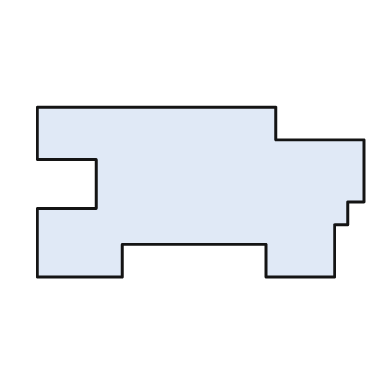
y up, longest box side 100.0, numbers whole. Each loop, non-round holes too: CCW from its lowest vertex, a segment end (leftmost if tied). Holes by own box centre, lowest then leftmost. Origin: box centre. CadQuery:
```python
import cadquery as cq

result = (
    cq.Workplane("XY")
    .moveTo(-50.0, -26.0)
    .lineTo(-24.0, -26.0)
    .lineTo(-24.0, -16.0)
    .lineTo(20.0, -16.0)
    .lineTo(20.0, -26.0)
    .lineTo(41.0, -26.0)
    .lineTo(41.0, -10.0)
    .lineTo(45.0, -10.0)
    .lineTo(45.0, -3.0)
    .lineTo(50.0, -3.0)
    .lineTo(50.0, 16.0)
    .lineTo(23.0, 16.0)
    .lineTo(23.0, 26.0)
    .lineTo(-50.0, 26.0)
    .lineTo(-50.0, 10.0)
    .lineTo(-32.0, 10.0)
    .lineTo(-32.0, -5.0)
    .lineTo(-50.0, -5.0)
    .close()
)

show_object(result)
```